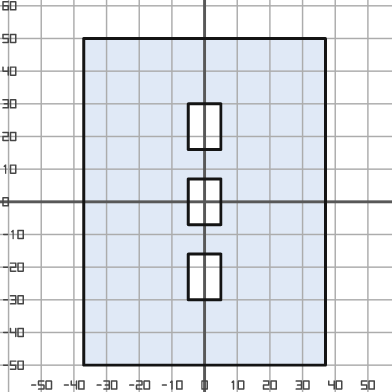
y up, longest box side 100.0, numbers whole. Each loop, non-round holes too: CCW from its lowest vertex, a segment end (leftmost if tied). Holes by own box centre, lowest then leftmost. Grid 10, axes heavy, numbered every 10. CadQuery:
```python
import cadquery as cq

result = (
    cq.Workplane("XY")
    .moveTo(-37.0, -50.0)
    .lineTo(37.0, -50.0)
    .lineTo(37.0, 50.0)
    .lineTo(-37.0, 50.0)
    .close()
    .moveTo(-5.0, -30.0)
    .lineTo(5.0, -30.0)
    .lineTo(5.0, -16.0)
    .lineTo(-5.0, -16.0)
    .close()
    .moveTo(-5.0, -7.0)
    .lineTo(5.0, -7.0)
    .lineTo(5.0, 7.0)
    .lineTo(-5.0, 7.0)
    .close()
    .moveTo(-5.0, 16.0)
    .lineTo(5.0, 16.0)
    .lineTo(5.0, 30.0)
    .lineTo(-5.0, 30.0)
    .close()
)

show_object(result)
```